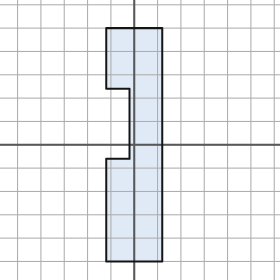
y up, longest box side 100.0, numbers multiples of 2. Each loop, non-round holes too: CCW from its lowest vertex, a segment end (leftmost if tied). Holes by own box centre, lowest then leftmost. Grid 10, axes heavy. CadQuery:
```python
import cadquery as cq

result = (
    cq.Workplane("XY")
    .moveTo(-12.0, -50.0)
    .lineTo(12.0, -50.0)
    .lineTo(12.0, 50.0)
    .lineTo(-12.0, 50.0)
    .lineTo(-12.0, 24.0)
    .lineTo(-2.0, 24.0)
    .lineTo(-2.0, -6.0)
    .lineTo(-12.0, -6.0)
    .close()
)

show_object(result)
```